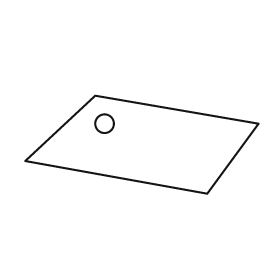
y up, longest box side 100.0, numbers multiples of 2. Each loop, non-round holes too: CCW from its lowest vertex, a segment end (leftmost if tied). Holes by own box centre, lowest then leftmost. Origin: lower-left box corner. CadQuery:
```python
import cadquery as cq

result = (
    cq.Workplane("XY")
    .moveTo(78.0, 0.0)
    .lineTo(100.0, 30.0)
    .lineTo(30.0, 42.0)
    .lineTo(0.0, 14.0)
    .close()
    .moveTo(34.0, 30.0)
    .circle(4.0)
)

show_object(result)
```